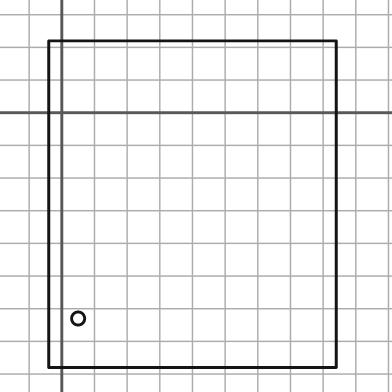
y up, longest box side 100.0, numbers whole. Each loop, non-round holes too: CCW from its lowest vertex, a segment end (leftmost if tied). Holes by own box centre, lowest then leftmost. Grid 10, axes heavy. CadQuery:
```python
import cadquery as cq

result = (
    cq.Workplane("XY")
    .moveTo(-4.0, -78.0)
    .lineTo(84.0, -78.0)
    .lineTo(84.0, 22.0)
    .lineTo(-4.0, 22.0)
    .close()
    .moveTo(5.0, -63.0)
    .circle(2.0)
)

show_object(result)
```